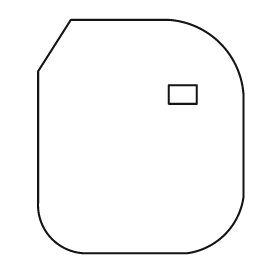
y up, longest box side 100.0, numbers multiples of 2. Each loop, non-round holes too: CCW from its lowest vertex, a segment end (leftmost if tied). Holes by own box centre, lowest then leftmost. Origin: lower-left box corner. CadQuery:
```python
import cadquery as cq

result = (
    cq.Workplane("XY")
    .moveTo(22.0, 0.0)
    .lineTo(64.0, 0.0)
    .threePointArc((80.0, 8.0), (88.0, 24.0))
    .lineTo(88.0, 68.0)
    .threePointArc((78.0, 90.0), (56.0, 100.0))
    .lineTo(14.0, 100.0)
    .lineTo(0.0, 78.0)
    .lineTo(0.0, 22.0)
    .threePointArc((6.0, 6.0), (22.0, 0.0))
    .close()
    .moveTo(56.0, 64.0)
    .lineTo(68.0, 64.0)
    .lineTo(68.0, 72.0)
    .lineTo(56.0, 72.0)
    .close()
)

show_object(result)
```